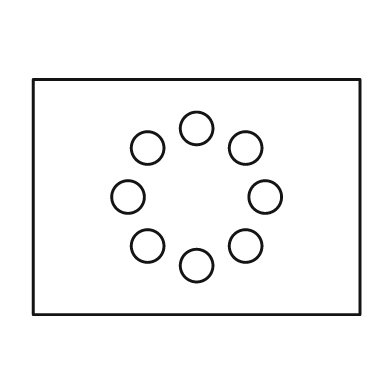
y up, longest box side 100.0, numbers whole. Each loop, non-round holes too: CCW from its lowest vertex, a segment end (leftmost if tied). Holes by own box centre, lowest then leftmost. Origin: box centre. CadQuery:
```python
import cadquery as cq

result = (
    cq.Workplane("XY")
    .moveTo(-50.0, -36.0)
    .lineTo(50.0, -36.0)
    .lineTo(50.0, 36.0)
    .lineTo(-50.0, 36.0)
    .close()
    .moveTo(0.0, -21.0)
    .circle(5.0)
    .moveTo(-15.0, -15.0)
    .circle(5.0)
    .moveTo(15.0, -15.0)
    .circle(5.0)
    .moveTo(-21.0, 0.0)
    .circle(5.0)
    .moveTo(21.0, 0.0)
    .circle(5.0)
    .moveTo(-15.0, 15.0)
    .circle(5.0)
    .moveTo(15.0, 15.0)
    .circle(5.0)
    .moveTo(0.0, 21.0)
    .circle(5.0)
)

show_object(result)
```